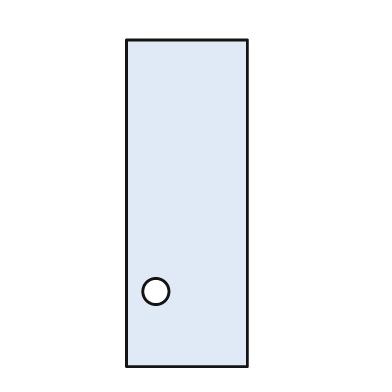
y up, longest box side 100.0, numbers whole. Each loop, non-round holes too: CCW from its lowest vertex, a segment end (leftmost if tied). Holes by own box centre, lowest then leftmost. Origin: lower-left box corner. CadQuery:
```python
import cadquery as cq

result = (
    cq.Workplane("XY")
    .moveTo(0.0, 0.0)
    .lineTo(37.0, 0.0)
    .lineTo(37.0, 100.0)
    .lineTo(0.0, 100.0)
    .close()
    .moveTo(9.0, 23.0)
    .circle(4.0)
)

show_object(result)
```